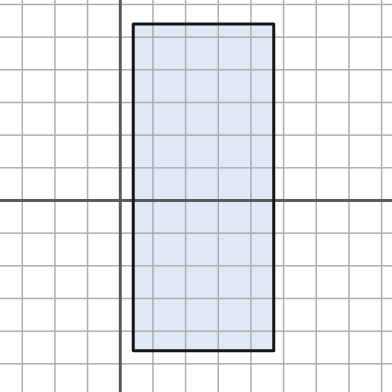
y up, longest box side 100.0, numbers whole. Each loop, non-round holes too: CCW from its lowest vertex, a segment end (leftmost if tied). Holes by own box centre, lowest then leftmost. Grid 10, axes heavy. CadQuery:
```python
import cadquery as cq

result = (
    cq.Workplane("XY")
    .moveTo(4.0, -46.0)
    .lineTo(47.0, -46.0)
    .lineTo(47.0, 54.0)
    .lineTo(4.0, 54.0)
    .close()
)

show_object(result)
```